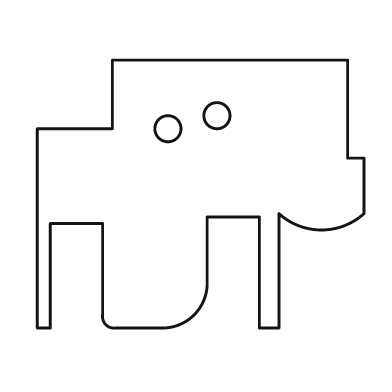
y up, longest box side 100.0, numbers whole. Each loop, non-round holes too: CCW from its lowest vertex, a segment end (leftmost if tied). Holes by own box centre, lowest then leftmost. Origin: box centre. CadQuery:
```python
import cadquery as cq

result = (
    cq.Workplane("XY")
    .moveTo(-50.0, -41.0)
    .lineTo(-46.0, -41.0)
    .lineTo(-46.0, -9.0)
    .lineTo(-30.0, -9.0)
    .lineTo(-30.0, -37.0)
    .threePointArc((-29.0, -40.0), (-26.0, -41.0))
    .lineTo(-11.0, -41.0)
    .threePointArc((-2.0, -37.0), (2.0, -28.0))
    .lineTo(2.0, -7.0)
    .lineTo(18.0, -7.0)
    .lineTo(18.0, -41.0)
    .lineTo(24.0, -41.0)
    .lineTo(24.0, -6.0)
    .threePointArc((37.0, -11.0), (50.0, -6.0))
    .lineTo(50.0, 11.0)
    .lineTo(45.0, 11.0)
    .lineTo(45.0, 41.0)
    .lineTo(-27.0, 41.0)
    .lineTo(-27.0, 20.0)
    .lineTo(-50.0, 20.0)
    .close()
    .moveTo(-10.0, 20.0)
    .circle(4.0)
    .moveTo(5.0, 24.0)
    .circle(4.0)
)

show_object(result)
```